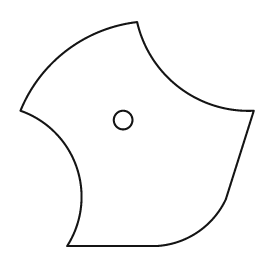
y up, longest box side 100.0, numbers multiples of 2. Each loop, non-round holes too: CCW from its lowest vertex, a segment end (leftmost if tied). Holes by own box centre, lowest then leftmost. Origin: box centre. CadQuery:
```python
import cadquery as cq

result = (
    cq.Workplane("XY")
    .moveTo(-30.0, -48.0)
    .lineTo(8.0, -48.0)
    .threePointArc((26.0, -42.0), (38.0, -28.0))
    .lineTo(50.0, 10.0)
    .threePointArc((18.0, 20.0), (0.0, 48.0))
    .threePointArc((-30.0, 36.0), (-50.0, 10.0))
    .threePointArc((-26.0, -14.0), (-30.0, -48.0))
    .close()
    .moveTo(-6.0, 6.0)
    .circle(4.0)
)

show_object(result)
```